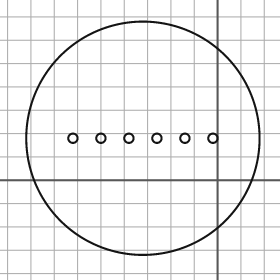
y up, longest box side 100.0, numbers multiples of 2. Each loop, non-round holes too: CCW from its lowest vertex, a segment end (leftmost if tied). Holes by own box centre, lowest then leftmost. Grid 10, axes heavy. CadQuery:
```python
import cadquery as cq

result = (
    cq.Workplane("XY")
    .moveTo(-32.0, 18.0)
    .circle(50.0)
    .moveTo(-62.0, 18.0)
    .circle(2.0)
    .moveTo(-50.0, 18.0)
    .circle(2.0)
    .moveTo(-38.0, 18.0)
    .circle(2.0)
    .moveTo(-26.0, 18.0)
    .circle(2.0)
    .moveTo(-14.0, 18.0)
    .circle(2.0)
    .moveTo(-2.0, 18.0)
    .circle(2.0)
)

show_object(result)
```